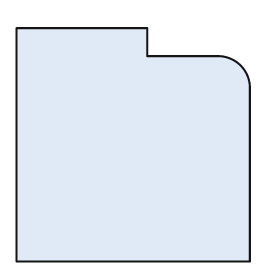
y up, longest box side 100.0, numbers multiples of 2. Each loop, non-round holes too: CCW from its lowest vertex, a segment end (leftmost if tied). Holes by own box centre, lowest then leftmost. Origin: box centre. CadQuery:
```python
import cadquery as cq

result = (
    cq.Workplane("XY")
    .moveTo(-50.0, -50.0)
    .lineTo(50.0, -50.0)
    .lineTo(50.0, 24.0)
    .threePointArc((46.0, 34.0), (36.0, 38.0))
    .lineTo(6.0, 38.0)
    .lineTo(6.0, 50.0)
    .lineTo(-50.0, 50.0)
    .close()
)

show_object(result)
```